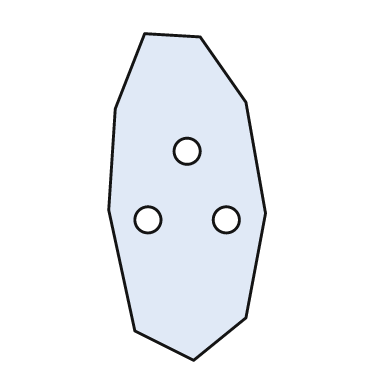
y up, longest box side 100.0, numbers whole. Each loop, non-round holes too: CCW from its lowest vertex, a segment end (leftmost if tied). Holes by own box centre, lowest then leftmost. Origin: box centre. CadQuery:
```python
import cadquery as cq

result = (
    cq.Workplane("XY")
    .moveTo(2.0, -50.0)
    .lineTo(18.0, -37.0)
    .lineTo(24.0, -5.0)
    .lineTo(18.0, 29.0)
    .lineTo(4.0, 49.0)
    .lineTo(-13.0, 50.0)
    .lineTo(-22.0, 27.0)
    .lineTo(-24.0, -4.0)
    .lineTo(-16.0, -41.0)
    .close()
    .moveTo(-12.0, -7.0)
    .circle(4.0)
    .moveTo(12.0, -7.0)
    .circle(4.0)
    .moveTo(0.0, 14.0)
    .circle(4.0)
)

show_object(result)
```